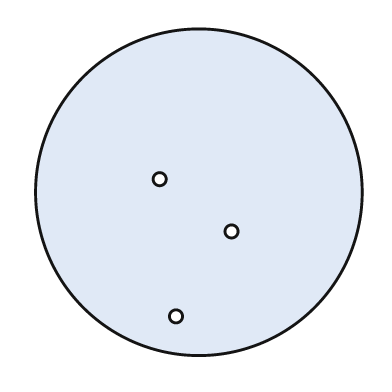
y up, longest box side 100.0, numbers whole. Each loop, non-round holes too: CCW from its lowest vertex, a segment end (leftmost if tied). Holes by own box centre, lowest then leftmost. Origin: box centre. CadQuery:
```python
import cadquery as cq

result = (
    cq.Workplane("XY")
    .moveTo(0.0, 0.0)
    .circle(50.0)
    .moveTo(-7.0, -38.0)
    .circle(2.0)
    .moveTo(10.0, -12.0)
    .circle(2.0)
    .moveTo(-12.0, 4.0)
    .circle(2.0)
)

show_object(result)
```